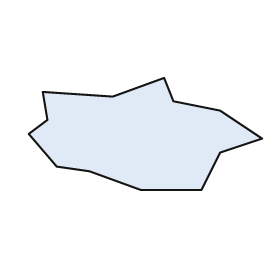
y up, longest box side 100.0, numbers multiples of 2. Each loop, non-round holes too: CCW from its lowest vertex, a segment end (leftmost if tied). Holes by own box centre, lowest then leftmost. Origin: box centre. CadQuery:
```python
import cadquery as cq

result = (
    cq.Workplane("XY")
    .moveTo(-2.0, -24.0)
    .lineTo(24.0, -24.0)
    .lineTo(32.0, -8.0)
    .lineTo(50.0, -2.0)
    .lineTo(32.0, 10.0)
    .lineTo(12.0, 14.0)
    .lineTo(8.0, 24.0)
    .lineTo(-14.0, 16.0)
    .lineTo(-44.0, 18.0)
    .lineTo(-42.0, 6.0)
    .lineTo(-50.0, 0.0)
    .lineTo(-38.0, -14.0)
    .lineTo(-24.0, -16.0)
    .close()
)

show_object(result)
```